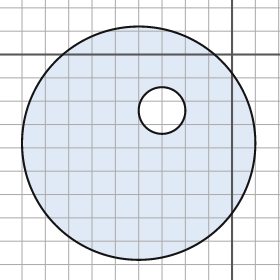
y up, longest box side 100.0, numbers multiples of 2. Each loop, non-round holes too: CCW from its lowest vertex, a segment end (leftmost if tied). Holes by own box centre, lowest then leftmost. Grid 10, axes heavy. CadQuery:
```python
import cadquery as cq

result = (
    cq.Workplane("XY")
    .moveTo(-40.0, -38.0)
    .circle(50.0)
    .moveTo(-30.0, -24.0)
    .circle(10.0)
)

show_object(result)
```